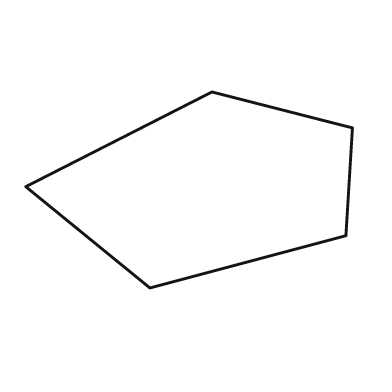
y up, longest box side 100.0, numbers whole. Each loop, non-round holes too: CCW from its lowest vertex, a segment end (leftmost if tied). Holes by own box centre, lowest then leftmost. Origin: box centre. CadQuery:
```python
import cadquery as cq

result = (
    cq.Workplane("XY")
    .moveTo(-12.0, -30.0)
    .lineTo(48.0, -14.0)
    .lineTo(50.0, 19.0)
    .lineTo(7.0, 30.0)
    .lineTo(-50.0, 1.0)
    .close()
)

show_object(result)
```